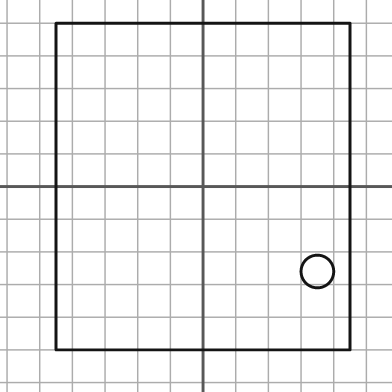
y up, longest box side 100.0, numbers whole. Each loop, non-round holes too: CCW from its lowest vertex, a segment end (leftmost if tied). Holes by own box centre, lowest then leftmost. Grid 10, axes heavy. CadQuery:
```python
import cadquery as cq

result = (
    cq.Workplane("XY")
    .moveTo(-45.0, -50.0)
    .lineTo(45.0, -50.0)
    .lineTo(45.0, 50.0)
    .lineTo(-45.0, 50.0)
    .close()
    .moveTo(35.0, -26.0)
    .circle(5.0)
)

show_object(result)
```